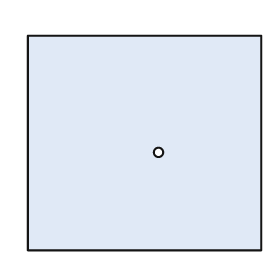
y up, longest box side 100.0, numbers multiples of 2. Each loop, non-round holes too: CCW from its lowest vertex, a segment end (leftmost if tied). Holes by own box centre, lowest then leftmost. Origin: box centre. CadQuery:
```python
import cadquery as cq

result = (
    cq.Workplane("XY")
    .moveTo(-50.0, -46.0)
    .lineTo(50.0, -46.0)
    .lineTo(50.0, 46.0)
    .lineTo(-50.0, 46.0)
    .close()
    .moveTo(6.0, -4.0)
    .circle(2.0)
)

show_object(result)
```